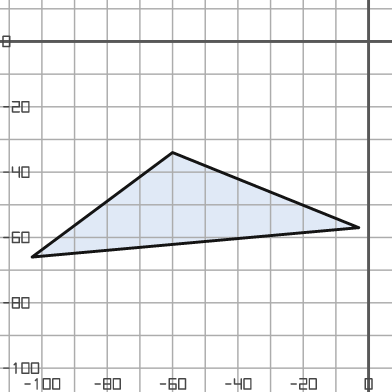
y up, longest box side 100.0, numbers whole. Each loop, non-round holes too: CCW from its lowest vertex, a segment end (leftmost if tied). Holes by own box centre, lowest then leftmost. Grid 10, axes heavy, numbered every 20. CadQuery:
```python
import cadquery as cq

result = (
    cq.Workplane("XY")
    .moveTo(-103.0, -66.0)
    .lineTo(-3.0, -57.0)
    .lineTo(-60.0, -34.0)
    .close()
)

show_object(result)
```